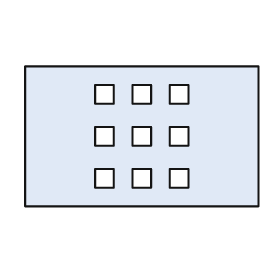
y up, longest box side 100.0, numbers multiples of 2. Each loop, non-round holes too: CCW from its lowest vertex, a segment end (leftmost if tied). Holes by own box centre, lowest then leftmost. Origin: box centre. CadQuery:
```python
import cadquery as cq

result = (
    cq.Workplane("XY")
    .moveTo(-50.0, -30.0)
    .lineTo(50.0, -30.0)
    .lineTo(50.0, 30.0)
    .lineTo(-50.0, 30.0)
    .close()
    .moveTo(-20.0, -22.0)
    .lineTo(-12.0, -22.0)
    .lineTo(-12.0, -14.0)
    .lineTo(-20.0, -14.0)
    .close()
    .moveTo(-4.0, -22.0)
    .lineTo(4.0, -22.0)
    .lineTo(4.0, -14.0)
    .lineTo(-4.0, -14.0)
    .close()
    .moveTo(12.0, -22.0)
    .lineTo(20.0, -22.0)
    .lineTo(20.0, -14.0)
    .lineTo(12.0, -14.0)
    .close()
    .moveTo(-20.0, -4.0)
    .lineTo(-12.0, -4.0)
    .lineTo(-12.0, 4.0)
    .lineTo(-20.0, 4.0)
    .close()
    .moveTo(-4.0, -4.0)
    .lineTo(4.0, -4.0)
    .lineTo(4.0, 4.0)
    .lineTo(-4.0, 4.0)
    .close()
    .moveTo(12.0, -4.0)
    .lineTo(20.0, -4.0)
    .lineTo(20.0, 4.0)
    .lineTo(12.0, 4.0)
    .close()
    .moveTo(-20.0, 14.0)
    .lineTo(-12.0, 14.0)
    .lineTo(-12.0, 22.0)
    .lineTo(-20.0, 22.0)
    .close()
    .moveTo(-4.0, 14.0)
    .lineTo(4.0, 14.0)
    .lineTo(4.0, 22.0)
    .lineTo(-4.0, 22.0)
    .close()
    .moveTo(12.0, 14.0)
    .lineTo(20.0, 14.0)
    .lineTo(20.0, 22.0)
    .lineTo(12.0, 22.0)
    .close()
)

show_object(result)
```